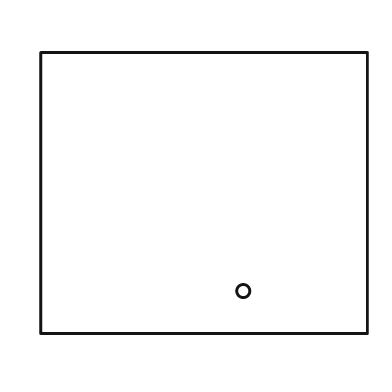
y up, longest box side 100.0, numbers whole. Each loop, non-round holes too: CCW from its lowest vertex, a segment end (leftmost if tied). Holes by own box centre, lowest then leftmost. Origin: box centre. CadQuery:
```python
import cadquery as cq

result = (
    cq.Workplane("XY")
    .moveTo(-50.0, -43.0)
    .lineTo(50.0, -43.0)
    .lineTo(50.0, 43.0)
    .lineTo(-50.0, 43.0)
    .close()
    .moveTo(12.0, -30.0)
    .circle(2.0)
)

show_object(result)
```